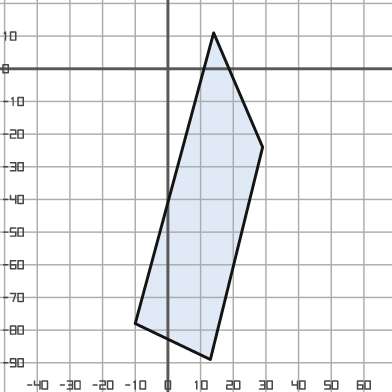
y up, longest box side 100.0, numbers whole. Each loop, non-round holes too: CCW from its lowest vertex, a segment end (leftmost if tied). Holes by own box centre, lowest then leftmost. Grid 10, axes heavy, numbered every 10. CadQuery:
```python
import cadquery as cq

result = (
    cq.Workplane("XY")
    .moveTo(13.0, -89.0)
    .lineTo(29.0, -24.0)
    .lineTo(14.0, 11.0)
    .lineTo(-10.0, -78.0)
    .close()
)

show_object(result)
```